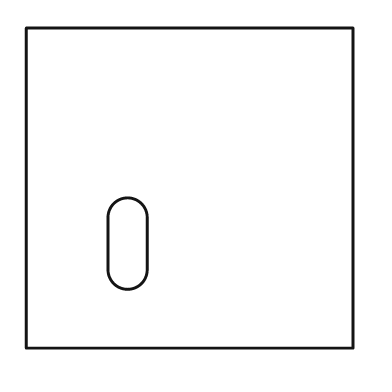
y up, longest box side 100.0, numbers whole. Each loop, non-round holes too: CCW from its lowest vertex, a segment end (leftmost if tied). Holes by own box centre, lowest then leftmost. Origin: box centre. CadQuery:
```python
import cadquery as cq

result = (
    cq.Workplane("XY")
    .moveTo(-50.0, -49.0)
    .lineTo(50.0, -49.0)
    .lineTo(50.0, 49.0)
    .lineTo(-50.0, 49.0)
    .close()
    .moveTo(-25.0, -25.0)
    .threePointArc((-19.0, -31.0), (-13.0, -25.0))
    .lineTo(-13.0, -9.0)
    .threePointArc((-19.0, -3.0), (-25.0, -9.0))
    .close()
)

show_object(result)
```